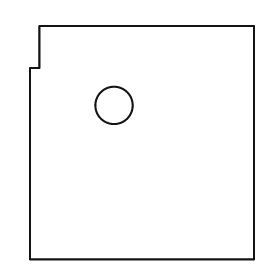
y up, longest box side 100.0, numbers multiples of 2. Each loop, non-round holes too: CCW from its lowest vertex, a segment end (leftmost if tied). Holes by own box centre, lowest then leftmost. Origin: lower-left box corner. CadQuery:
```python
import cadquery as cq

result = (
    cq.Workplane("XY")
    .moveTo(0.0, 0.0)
    .lineTo(96.0, 0.0)
    .lineTo(96.0, 100.0)
    .lineTo(4.0, 100.0)
    .lineTo(4.0, 82.0)
    .lineTo(0.0, 82.0)
    .close()
    .moveTo(36.0, 66.0)
    .circle(8.0)
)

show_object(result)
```